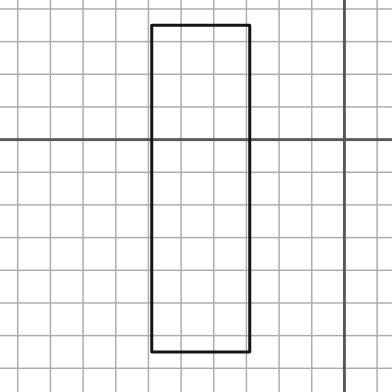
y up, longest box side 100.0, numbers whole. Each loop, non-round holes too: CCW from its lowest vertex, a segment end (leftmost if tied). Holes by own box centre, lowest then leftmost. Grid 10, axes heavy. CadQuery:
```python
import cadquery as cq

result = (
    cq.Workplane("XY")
    .moveTo(-59.0, -65.0)
    .lineTo(-29.0, -65.0)
    .lineTo(-29.0, 35.0)
    .lineTo(-59.0, 35.0)
    .close()
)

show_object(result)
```